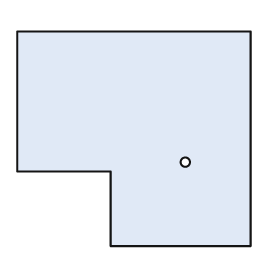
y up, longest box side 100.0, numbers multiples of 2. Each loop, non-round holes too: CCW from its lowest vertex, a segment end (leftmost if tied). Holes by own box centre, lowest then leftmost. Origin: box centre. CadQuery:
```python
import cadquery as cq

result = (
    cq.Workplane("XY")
    .moveTo(-10.0, -46.0)
    .lineTo(50.0, -46.0)
    .lineTo(50.0, 46.0)
    .lineTo(-50.0, 46.0)
    .lineTo(-50.0, -14.0)
    .lineTo(-10.0, -14.0)
    .close()
    .moveTo(22.0, -10.0)
    .circle(2.0)
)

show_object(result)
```